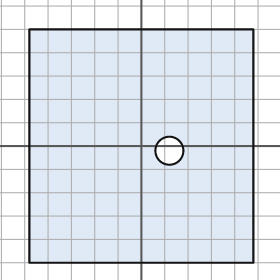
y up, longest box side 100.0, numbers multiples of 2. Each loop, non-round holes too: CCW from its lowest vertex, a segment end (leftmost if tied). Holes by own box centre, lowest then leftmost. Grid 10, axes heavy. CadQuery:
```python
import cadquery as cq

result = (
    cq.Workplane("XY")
    .moveTo(-48.0, -50.0)
    .lineTo(48.0, -50.0)
    .lineTo(48.0, 50.0)
    .lineTo(-48.0, 50.0)
    .close()
    .moveTo(12.0, -2.0)
    .circle(6.0)
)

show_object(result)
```